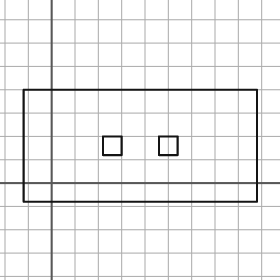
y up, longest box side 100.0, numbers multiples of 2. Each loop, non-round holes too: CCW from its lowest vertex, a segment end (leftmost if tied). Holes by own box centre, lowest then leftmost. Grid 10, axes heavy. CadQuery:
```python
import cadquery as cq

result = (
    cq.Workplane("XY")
    .moveTo(-12.0, -8.0)
    .lineTo(88.0, -8.0)
    .lineTo(88.0, 40.0)
    .lineTo(-12.0, 40.0)
    .close()
    .moveTo(22.0, 12.0)
    .lineTo(30.0, 12.0)
    .lineTo(30.0, 20.0)
    .lineTo(22.0, 20.0)
    .close()
    .moveTo(46.0, 12.0)
    .lineTo(54.0, 12.0)
    .lineTo(54.0, 20.0)
    .lineTo(46.0, 20.0)
    .close()
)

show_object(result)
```